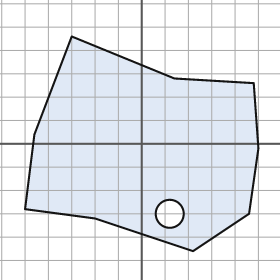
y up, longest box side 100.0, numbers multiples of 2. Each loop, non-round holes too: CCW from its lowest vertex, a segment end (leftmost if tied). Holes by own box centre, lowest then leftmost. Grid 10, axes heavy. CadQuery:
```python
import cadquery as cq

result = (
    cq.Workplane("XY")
    .moveTo(22.0, -46.0)
    .lineTo(46.0, -30.0)
    .lineTo(50.0, -2.0)
    .lineTo(48.0, 26.0)
    .lineTo(14.0, 28.0)
    .lineTo(-30.0, 46.0)
    .lineTo(-46.0, 4.0)
    .lineTo(-50.0, -28.0)
    .lineTo(-20.0, -32.0)
    .close()
    .moveTo(12.0, -30.0)
    .circle(6.0)
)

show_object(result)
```